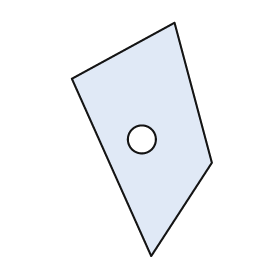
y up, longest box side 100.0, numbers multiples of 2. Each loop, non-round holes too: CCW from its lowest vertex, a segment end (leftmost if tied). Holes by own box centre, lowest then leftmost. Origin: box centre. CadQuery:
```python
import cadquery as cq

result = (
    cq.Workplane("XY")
    .moveTo(4.0, -50.0)
    .lineTo(30.0, -10.0)
    .lineTo(14.0, 50.0)
    .lineTo(-30.0, 26.0)
    .close()
    .moveTo(0.0, 0.0)
    .circle(6.0)
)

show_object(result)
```